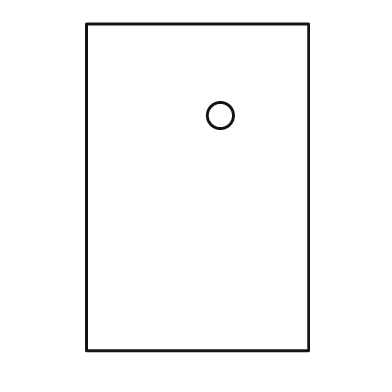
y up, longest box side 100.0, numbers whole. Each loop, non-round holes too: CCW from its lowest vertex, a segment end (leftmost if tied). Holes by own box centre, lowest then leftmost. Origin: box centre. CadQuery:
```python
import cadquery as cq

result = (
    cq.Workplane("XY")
    .moveTo(-34.0, -50.0)
    .lineTo(34.0, -50.0)
    .lineTo(34.0, 50.0)
    .lineTo(-34.0, 50.0)
    .close()
    .moveTo(7.0, 22.0)
    .circle(4.0)
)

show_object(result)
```